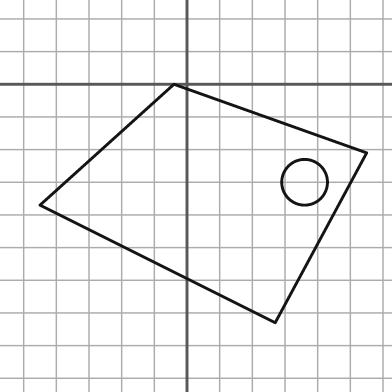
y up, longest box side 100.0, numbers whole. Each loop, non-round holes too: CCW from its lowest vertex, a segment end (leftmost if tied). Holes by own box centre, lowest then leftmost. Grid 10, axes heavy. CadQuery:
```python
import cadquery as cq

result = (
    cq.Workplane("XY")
    .moveTo(27.0, -73.0)
    .lineTo(55.0, -21.0)
    .lineTo(-4.0, 0.0)
    .lineTo(-45.0, -37.0)
    .close()
    .moveTo(36.0, -30.0)
    .circle(7.0)
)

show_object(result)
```